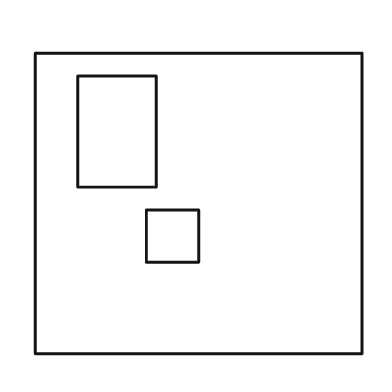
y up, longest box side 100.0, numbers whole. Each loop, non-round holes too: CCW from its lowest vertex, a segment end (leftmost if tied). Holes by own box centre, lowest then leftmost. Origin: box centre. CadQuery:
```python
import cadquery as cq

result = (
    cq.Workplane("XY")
    .moveTo(-50.0, -46.0)
    .lineTo(50.0, -46.0)
    .lineTo(50.0, 46.0)
    .lineTo(-50.0, 46.0)
    .close()
    .moveTo(-16.0, -18.0)
    .lineTo(0.0, -18.0)
    .lineTo(0.0, -2.0)
    .lineTo(-16.0, -2.0)
    .close()
    .moveTo(-37.0, 5.0)
    .lineTo(-13.0, 5.0)
    .lineTo(-13.0, 39.0)
    .lineTo(-37.0, 39.0)
    .close()
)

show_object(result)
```